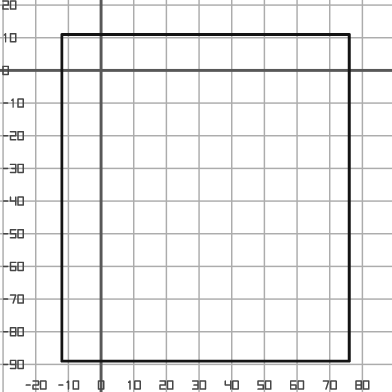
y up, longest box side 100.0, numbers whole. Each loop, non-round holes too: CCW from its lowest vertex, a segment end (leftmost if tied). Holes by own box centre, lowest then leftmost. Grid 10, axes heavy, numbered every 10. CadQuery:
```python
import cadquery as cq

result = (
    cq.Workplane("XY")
    .moveTo(-12.0, -89.0)
    .lineTo(76.0, -89.0)
    .lineTo(76.0, 11.0)
    .lineTo(-12.0, 11.0)
    .close()
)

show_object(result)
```